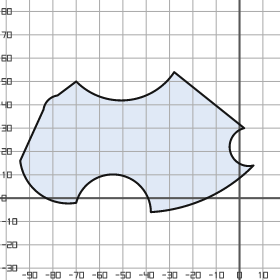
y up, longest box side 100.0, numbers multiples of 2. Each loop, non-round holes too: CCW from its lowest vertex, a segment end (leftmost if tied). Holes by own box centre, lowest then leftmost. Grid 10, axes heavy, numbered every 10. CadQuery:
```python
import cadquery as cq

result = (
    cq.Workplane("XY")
    .moveTo(-38.0, -6.0)
    .threePointArc((-14.0, 0.0), (6.0, 14.0))
    .threePointArc((-4.0, 20.0), (2.0, 30.0))
    .lineTo(-28.0, 54.0)
    .threePointArc((-48.0, 42.0), (-70.0, 50.0))
    .lineTo(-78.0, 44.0)
    .threePointArc((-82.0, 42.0), (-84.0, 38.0))
    .lineTo(-94.0, 16.0)
    .threePointArc((-86.0, 2.0), (-70.0, -2.0))
    .threePointArc((-52.0, 10.0), (-38.0, -6.0))
    .close()
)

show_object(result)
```